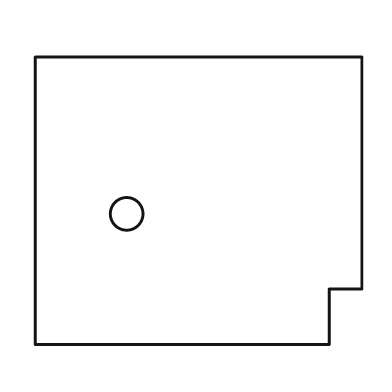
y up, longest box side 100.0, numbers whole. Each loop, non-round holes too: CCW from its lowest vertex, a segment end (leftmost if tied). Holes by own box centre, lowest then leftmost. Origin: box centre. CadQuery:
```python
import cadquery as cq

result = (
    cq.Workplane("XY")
    .moveTo(-50.0, -44.0)
    .lineTo(40.0, -44.0)
    .lineTo(40.0, -27.0)
    .lineTo(50.0, -27.0)
    .lineTo(50.0, 44.0)
    .lineTo(-50.0, 44.0)
    .close()
    .moveTo(-22.0, -4.0)
    .circle(5.0)
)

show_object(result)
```